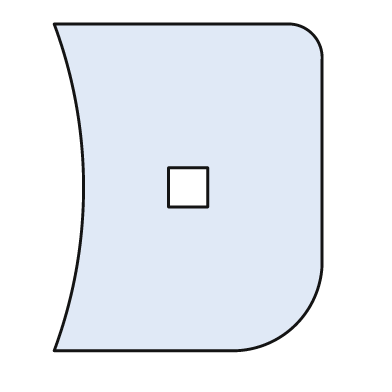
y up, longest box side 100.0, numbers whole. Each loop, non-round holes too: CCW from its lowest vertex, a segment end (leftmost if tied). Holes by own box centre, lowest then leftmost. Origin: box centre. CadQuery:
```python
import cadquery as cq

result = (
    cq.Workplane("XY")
    .moveTo(-41.0, -50.0)
    .lineTo(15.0, -50.0)
    .threePointArc((33.0, -42.0), (41.0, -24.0))
    .lineTo(41.0, 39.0)
    .threePointArc((38.0, 47.0), (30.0, 50.0))
    .lineTo(-41.0, 50.0)
    .threePointArc((-32.0, 0.0), (-41.0, -50.0))
    .close()
    .moveTo(-6.0, -6.0)
    .lineTo(6.0, -6.0)
    .lineTo(6.0, 6.0)
    .lineTo(-6.0, 6.0)
    .close()
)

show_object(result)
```